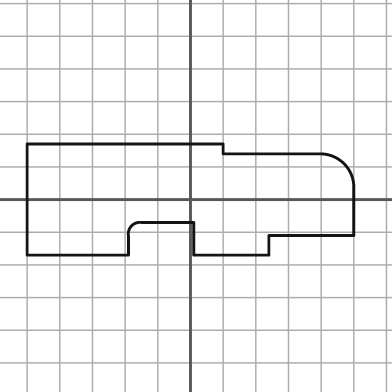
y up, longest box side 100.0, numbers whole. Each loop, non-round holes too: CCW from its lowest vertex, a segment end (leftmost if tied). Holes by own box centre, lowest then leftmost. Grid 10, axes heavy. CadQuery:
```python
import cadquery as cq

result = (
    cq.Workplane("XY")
    .moveTo(-50.0, -17.0)
    .lineTo(-19.0, -17.0)
    .lineTo(-19.0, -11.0)
    .threePointArc((-18.0, -8.0), (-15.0, -7.0))
    .lineTo(1.0, -7.0)
    .lineTo(1.0, -17.0)
    .lineTo(24.0, -17.0)
    .lineTo(24.0, -11.0)
    .lineTo(50.0, -11.0)
    .lineTo(50.0, 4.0)
    .threePointArc((47.0, 11.0), (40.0, 14.0))
    .lineTo(10.0, 14.0)
    .lineTo(10.0, 17.0)
    .lineTo(-50.0, 17.0)
    .close()
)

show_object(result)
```